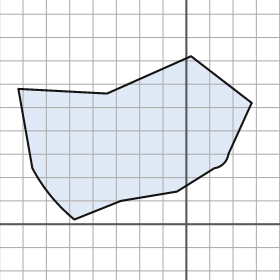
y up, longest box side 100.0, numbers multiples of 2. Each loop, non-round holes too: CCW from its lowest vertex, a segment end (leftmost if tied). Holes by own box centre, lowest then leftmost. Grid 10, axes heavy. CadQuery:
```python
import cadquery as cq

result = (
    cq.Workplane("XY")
    .moveTo(-48.0, 2.0)
    .lineTo(-28.0, 10.0)
    .lineTo(-4.0, 14.0)
    .lineTo(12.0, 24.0)
    .threePointArc((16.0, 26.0), (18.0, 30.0))
    .lineTo(28.0, 52.0)
    .lineTo(2.0, 72.0)
    .lineTo(-34.0, 56.0)
    .lineTo(-72.0, 58.0)
    .lineTo(-66.0, 24.0)
    .threePointArc((-58.0, 12.0), (-48.0, 2.0))
    .close()
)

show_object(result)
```